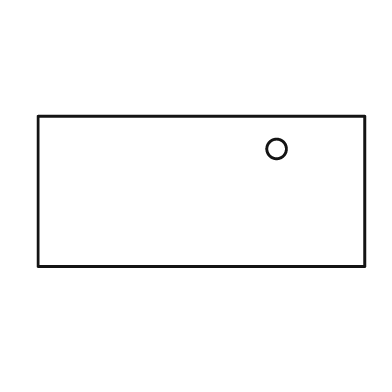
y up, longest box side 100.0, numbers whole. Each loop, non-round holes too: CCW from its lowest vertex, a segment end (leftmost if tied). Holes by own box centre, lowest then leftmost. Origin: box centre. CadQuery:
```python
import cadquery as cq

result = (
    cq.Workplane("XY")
    .moveTo(-50.0, -23.0)
    .lineTo(50.0, -23.0)
    .lineTo(50.0, 23.0)
    .lineTo(-50.0, 23.0)
    .close()
    .moveTo(23.0, 13.0)
    .circle(3.0)
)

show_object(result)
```